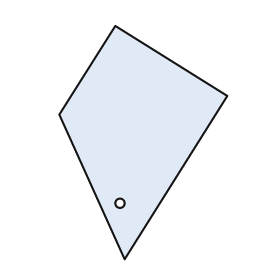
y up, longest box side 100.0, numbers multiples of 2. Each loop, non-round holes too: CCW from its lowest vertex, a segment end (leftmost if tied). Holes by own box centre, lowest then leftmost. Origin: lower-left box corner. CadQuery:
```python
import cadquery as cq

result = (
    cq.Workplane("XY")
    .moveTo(28.0, 0.0)
    .lineTo(72.0, 70.0)
    .lineTo(24.0, 100.0)
    .lineTo(0.0, 62.0)
    .close()
    .moveTo(26.0, 24.0)
    .circle(2.0)
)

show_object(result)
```